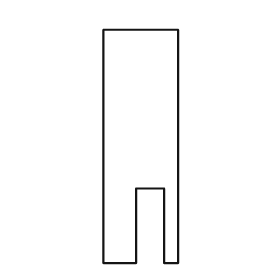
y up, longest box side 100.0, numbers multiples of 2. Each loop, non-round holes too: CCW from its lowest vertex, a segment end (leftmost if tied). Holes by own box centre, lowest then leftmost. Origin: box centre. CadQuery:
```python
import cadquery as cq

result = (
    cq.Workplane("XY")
    .moveTo(-16.0, -50.0)
    .lineTo(-2.0, -50.0)
    .lineTo(-2.0, -18.0)
    .lineTo(10.0, -18.0)
    .lineTo(10.0, -50.0)
    .lineTo(16.0, -50.0)
    .lineTo(16.0, 50.0)
    .lineTo(-16.0, 50.0)
    .close()
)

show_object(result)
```